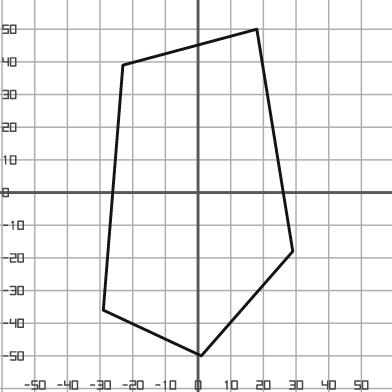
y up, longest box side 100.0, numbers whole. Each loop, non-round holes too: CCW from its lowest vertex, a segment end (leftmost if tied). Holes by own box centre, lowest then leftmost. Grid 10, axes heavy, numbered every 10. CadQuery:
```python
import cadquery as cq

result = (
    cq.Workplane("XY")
    .moveTo(1.0, -50.0)
    .lineTo(29.0, -18.0)
    .lineTo(18.0, 50.0)
    .lineTo(-23.0, 39.0)
    .lineTo(-29.0, -36.0)
    .close()
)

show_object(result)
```